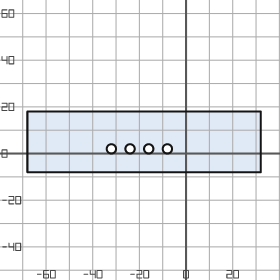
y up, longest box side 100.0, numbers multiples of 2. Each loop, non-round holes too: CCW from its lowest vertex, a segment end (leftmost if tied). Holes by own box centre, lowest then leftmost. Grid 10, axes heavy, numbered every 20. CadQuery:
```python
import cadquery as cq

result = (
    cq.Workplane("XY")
    .moveTo(-68.0, -8.0)
    .lineTo(32.0, -8.0)
    .lineTo(32.0, 18.0)
    .lineTo(-68.0, 18.0)
    .close()
    .moveTo(-32.0, 2.0)
    .circle(2.0)
    .moveTo(-24.0, 2.0)
    .circle(2.0)
    .moveTo(-16.0, 2.0)
    .circle(2.0)
    .moveTo(-8.0, 2.0)
    .circle(2.0)
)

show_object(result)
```